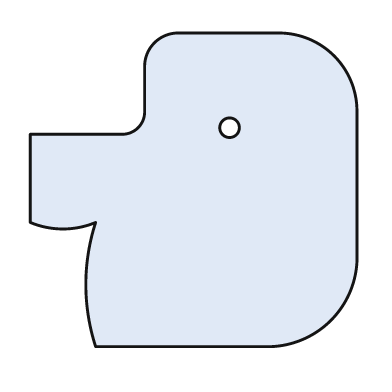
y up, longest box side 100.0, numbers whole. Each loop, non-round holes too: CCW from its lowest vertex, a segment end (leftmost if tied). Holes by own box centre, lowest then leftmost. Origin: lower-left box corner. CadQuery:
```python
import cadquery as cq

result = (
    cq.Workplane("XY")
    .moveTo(20.0, 0.0)
    .lineTo(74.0, 0.0)
    .threePointArc((92.0, 8.0), (100.0, 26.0))
    .lineTo(100.0, 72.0)
    .threePointArc((93.0, 89.0), (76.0, 96.0))
    .lineTo(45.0, 96.0)
    .threePointArc((38.0, 93.0), (35.0, 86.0))
    .lineTo(35.0, 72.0)
    .threePointArc((33.0, 67.0), (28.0, 65.0))
    .lineTo(0.0, 65.0)
    .lineTo(0.0, 38.0)
    .threePointArc((10.0, 36.0), (20.0, 38.0))
    .threePointArc((17.0, 19.0), (20.0, 0.0))
    .close()
    .moveTo(61.0, 67.0)
    .circle(3.0)
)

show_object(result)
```